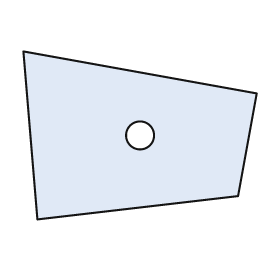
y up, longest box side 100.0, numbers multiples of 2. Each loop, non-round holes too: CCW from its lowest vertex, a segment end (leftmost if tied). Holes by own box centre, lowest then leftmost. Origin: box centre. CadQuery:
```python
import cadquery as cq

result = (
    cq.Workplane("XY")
    .moveTo(-44.0, -36.0)
    .lineTo(42.0, -26.0)
    .lineTo(50.0, 18.0)
    .lineTo(-50.0, 36.0)
    .close()
    .moveTo(0.0, 0.0)
    .circle(6.0)
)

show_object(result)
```